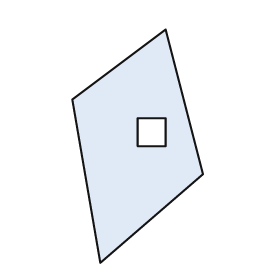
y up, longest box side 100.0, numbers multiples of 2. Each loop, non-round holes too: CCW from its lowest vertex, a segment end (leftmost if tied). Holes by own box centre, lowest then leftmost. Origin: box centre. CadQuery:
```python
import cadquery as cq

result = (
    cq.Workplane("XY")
    .moveTo(-16.0, -50.0)
    .lineTo(28.0, -12.0)
    .lineTo(12.0, 50.0)
    .lineTo(-28.0, 20.0)
    .close()
    .moveTo(0.0, 0.0)
    .lineTo(12.0, 0.0)
    .lineTo(12.0, 12.0)
    .lineTo(0.0, 12.0)
    .close()
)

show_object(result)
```